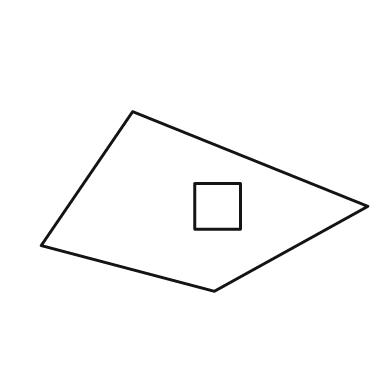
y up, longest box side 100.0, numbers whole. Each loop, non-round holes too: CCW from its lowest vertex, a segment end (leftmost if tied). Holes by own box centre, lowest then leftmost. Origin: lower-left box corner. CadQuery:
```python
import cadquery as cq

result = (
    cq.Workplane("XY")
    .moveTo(53.0, 0.0)
    .lineTo(100.0, 26.0)
    .lineTo(28.0, 55.0)
    .lineTo(0.0, 14.0)
    .close()
    .moveTo(47.0, 19.0)
    .lineTo(61.0, 19.0)
    .lineTo(61.0, 33.0)
    .lineTo(47.0, 33.0)
    .close()
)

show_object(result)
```